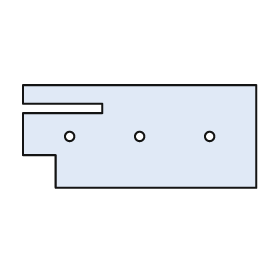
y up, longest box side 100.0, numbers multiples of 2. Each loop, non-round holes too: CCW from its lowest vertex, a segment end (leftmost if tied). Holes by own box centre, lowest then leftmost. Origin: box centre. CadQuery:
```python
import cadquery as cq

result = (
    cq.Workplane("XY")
    .moveTo(-36.0, -22.0)
    .lineTo(50.0, -22.0)
    .lineTo(50.0, 22.0)
    .lineTo(-50.0, 22.0)
    .lineTo(-50.0, 14.0)
    .lineTo(-16.0, 14.0)
    .lineTo(-16.0, 10.0)
    .lineTo(-50.0, 10.0)
    .lineTo(-50.0, -8.0)
    .lineTo(-36.0, -8.0)
    .close()
    .moveTo(-30.0, 0.0)
    .circle(2.0)
    .moveTo(0.0, 0.0)
    .circle(2.0)
    .moveTo(30.0, 0.0)
    .circle(2.0)
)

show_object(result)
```